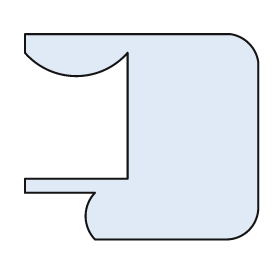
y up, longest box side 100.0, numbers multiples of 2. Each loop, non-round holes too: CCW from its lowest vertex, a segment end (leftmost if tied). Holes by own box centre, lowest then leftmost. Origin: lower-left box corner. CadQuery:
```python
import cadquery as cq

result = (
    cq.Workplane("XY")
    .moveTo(30.0, 0.0)
    .lineTo(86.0, 0.0)
    .threePointArc((96.0, 4.0), (100.0, 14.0))
    .lineTo(100.0, 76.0)
    .threePointArc((96.0, 84.0), (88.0, 88.0))
    .lineTo(0.0, 88.0)
    .lineTo(0.0, 80.0)
    .threePointArc((22.0, 70.0), (44.0, 80.0))
    .lineTo(44.0, 26.0)
    .lineTo(0.0, 26.0)
    .lineTo(0.0, 20.0)
    .lineTo(30.0, 20.0)
    .threePointArc((26.0, 10.0), (30.0, 0.0))
    .close()
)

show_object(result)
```